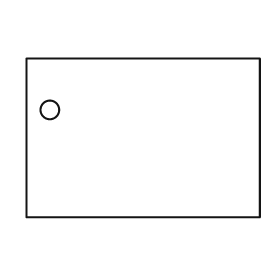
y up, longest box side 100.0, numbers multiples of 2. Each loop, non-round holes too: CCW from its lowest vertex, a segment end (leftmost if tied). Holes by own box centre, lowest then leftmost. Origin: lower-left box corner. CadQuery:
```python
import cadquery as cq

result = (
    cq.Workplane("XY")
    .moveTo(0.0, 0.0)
    .lineTo(100.0, 0.0)
    .lineTo(100.0, 68.0)
    .lineTo(0.0, 68.0)
    .close()
    .moveTo(10.0, 46.0)
    .circle(4.0)
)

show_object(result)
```